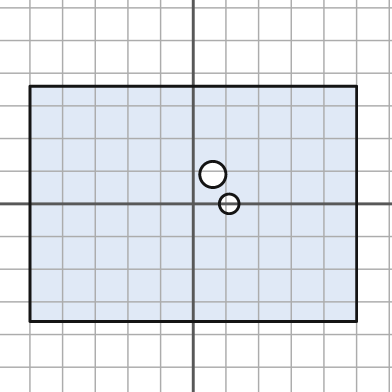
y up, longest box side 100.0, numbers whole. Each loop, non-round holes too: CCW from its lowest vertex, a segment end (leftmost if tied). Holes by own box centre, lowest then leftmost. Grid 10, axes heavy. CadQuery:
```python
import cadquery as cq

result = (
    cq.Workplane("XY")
    .moveTo(-50.0, -36.0)
    .lineTo(50.0, -36.0)
    .lineTo(50.0, 36.0)
    .lineTo(-50.0, 36.0)
    .close()
    .moveTo(11.0, 0.0)
    .circle(3.0)
    .moveTo(6.0, 9.0)
    .circle(4.0)
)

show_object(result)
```